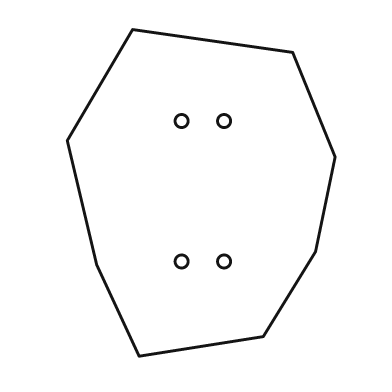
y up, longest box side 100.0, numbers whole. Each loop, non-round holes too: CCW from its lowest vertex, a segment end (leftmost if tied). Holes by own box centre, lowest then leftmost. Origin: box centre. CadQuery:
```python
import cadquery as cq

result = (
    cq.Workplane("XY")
    .moveTo(-19.0, -50.0)
    .lineTo(19.0, -44.0)
    .lineTo(35.0, -18.0)
    .lineTo(41.0, 11.0)
    .lineTo(28.0, 43.0)
    .lineTo(-21.0, 50.0)
    .lineTo(-41.0, 16.0)
    .lineTo(-32.0, -22.0)
    .close()
    .moveTo(-6.0, -21.0)
    .circle(2.0)
    .moveTo(7.0, -21.0)
    .circle(2.0)
    .moveTo(-6.0, 22.0)
    .circle(2.0)
    .moveTo(7.0, 22.0)
    .circle(2.0)
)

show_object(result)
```